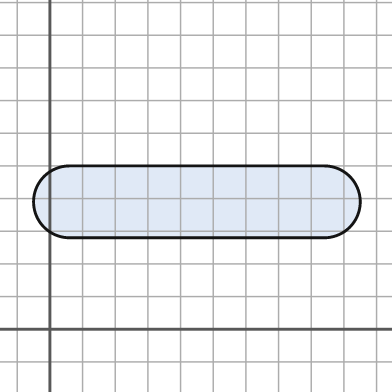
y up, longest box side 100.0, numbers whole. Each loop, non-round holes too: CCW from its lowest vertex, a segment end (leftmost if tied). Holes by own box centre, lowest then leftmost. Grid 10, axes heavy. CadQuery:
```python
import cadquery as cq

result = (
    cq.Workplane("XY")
    .moveTo(6.0, 28.0)
    .lineTo(84.0, 28.0)
    .threePointArc((95.0, 39.0), (84.0, 50.0))
    .lineTo(6.0, 50.0)
    .threePointArc((-5.0, 39.0), (6.0, 28.0))
    .close()
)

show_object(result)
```